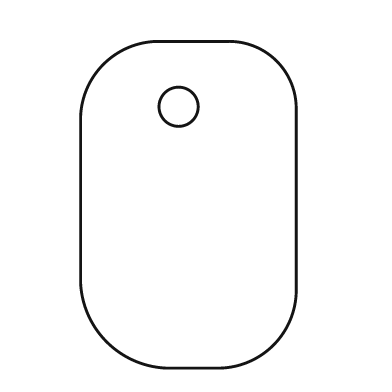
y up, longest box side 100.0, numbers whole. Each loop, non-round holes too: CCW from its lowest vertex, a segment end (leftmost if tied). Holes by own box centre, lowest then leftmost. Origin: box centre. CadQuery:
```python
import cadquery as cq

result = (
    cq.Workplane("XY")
    .moveTo(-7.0, -50.0)
    .lineTo(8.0, -50.0)
    .threePointArc((26.0, -43.0), (33.0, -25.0))
    .lineTo(33.0, 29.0)
    .threePointArc((27.0, 44.0), (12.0, 50.0))
    .lineTo(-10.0, 50.0)
    .threePointArc((-26.0, 43.0), (-33.0, 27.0))
    .lineTo(-33.0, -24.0)
    .threePointArc((-25.0, -42.0), (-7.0, -50.0))
    .close()
    .moveTo(-3.0, 30.0)
    .circle(6.0)
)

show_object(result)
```